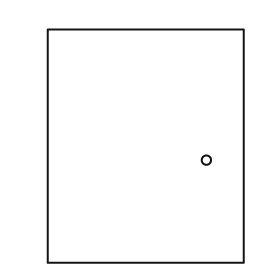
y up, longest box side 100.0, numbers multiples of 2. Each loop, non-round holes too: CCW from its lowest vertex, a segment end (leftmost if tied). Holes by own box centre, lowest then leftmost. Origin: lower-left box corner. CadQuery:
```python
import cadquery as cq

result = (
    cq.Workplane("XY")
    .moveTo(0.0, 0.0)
    .lineTo(84.0, 0.0)
    .lineTo(84.0, 100.0)
    .lineTo(0.0, 100.0)
    .close()
    .moveTo(68.0, 44.0)
    .circle(2.0)
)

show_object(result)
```